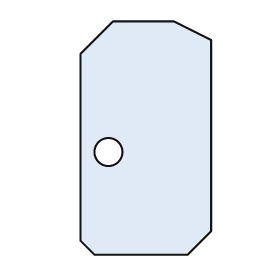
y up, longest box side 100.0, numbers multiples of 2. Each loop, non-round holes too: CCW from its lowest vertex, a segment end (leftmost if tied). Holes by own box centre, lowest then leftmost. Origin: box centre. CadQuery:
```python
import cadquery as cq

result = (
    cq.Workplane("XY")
    .moveTo(-22.0, -50.0)
    .lineTo(18.0, -50.0)
    .lineTo(28.0, -40.0)
    .lineTo(28.0, 42.0)
    .lineTo(12.0, 50.0)
    .lineTo(-14.0, 50.0)
    .lineTo(-28.0, 36.0)
    .lineTo(-28.0, -44.0)
    .close()
    .moveTo(-16.0, -6.0)
    .circle(6.0)
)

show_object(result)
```